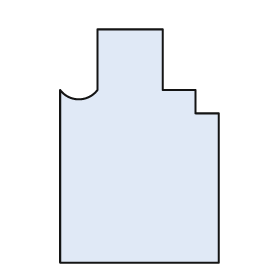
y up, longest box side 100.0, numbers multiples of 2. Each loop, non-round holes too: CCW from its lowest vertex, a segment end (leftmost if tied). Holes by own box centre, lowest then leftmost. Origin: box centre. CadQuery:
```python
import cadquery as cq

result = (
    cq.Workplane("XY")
    .moveTo(-34.0, -50.0)
    .lineTo(34.0, -50.0)
    .lineTo(34.0, 14.0)
    .lineTo(24.0, 14.0)
    .lineTo(24.0, 24.0)
    .lineTo(10.0, 24.0)
    .lineTo(10.0, 50.0)
    .lineTo(-18.0, 50.0)
    .lineTo(-18.0, 24.0)
    .threePointArc((-26.0, 20.0), (-34.0, 24.0))
    .close()
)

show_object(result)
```